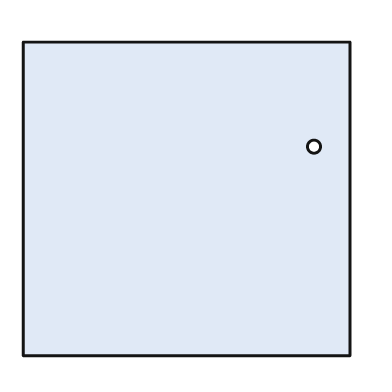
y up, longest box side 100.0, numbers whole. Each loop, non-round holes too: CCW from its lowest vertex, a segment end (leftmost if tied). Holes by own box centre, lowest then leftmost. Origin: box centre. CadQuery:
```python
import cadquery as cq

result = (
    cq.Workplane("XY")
    .moveTo(-50.0, -48.0)
    .lineTo(50.0, -48.0)
    .lineTo(50.0, 48.0)
    .lineTo(-50.0, 48.0)
    .close()
    .moveTo(39.0, 16.0)
    .circle(2.0)
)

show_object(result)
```